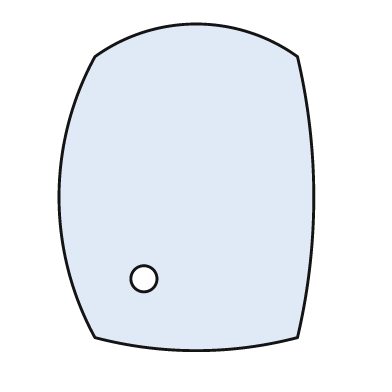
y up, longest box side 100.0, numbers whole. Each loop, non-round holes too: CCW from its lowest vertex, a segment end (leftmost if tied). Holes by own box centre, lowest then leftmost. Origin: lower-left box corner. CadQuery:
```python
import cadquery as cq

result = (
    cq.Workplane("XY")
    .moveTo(11.0, 4.0)
    .threePointArc((42.0, 0.0), (73.0, 4.0))
    .threePointArc((78.0, 47.0), (73.0, 90.0))
    .threePointArc((42.0, 100.0), (11.0, 90.0))
    .threePointArc((0.0, 47.0), (11.0, 4.0))
    .close()
    .moveTo(26.0, 22.0)
    .circle(4.0)
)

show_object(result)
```